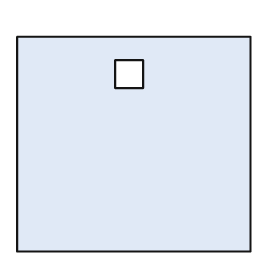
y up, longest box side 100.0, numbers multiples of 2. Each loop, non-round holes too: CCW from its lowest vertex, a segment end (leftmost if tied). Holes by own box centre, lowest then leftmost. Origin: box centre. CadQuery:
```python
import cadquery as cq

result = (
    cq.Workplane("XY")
    .moveTo(-50.0, -46.0)
    .lineTo(50.0, -46.0)
    .lineTo(50.0, 46.0)
    .lineTo(-50.0, 46.0)
    .close()
    .moveTo(-8.0, 24.0)
    .lineTo(4.0, 24.0)
    .lineTo(4.0, 36.0)
    .lineTo(-8.0, 36.0)
    .close()
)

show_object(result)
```